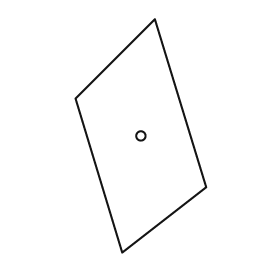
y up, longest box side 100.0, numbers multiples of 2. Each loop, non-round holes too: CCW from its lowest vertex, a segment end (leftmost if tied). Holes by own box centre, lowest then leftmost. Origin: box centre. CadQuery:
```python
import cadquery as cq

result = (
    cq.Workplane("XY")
    .moveTo(-8.0, -50.0)
    .lineTo(28.0, -22.0)
    .lineTo(6.0, 50.0)
    .lineTo(-28.0, 16.0)
    .close()
    .moveTo(0.0, 0.0)
    .circle(2.0)
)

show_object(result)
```